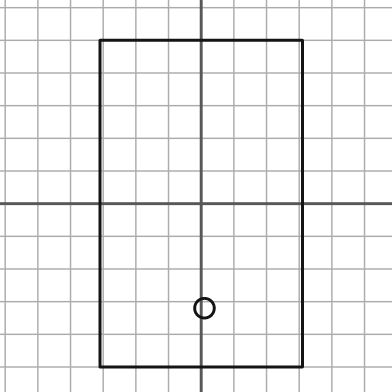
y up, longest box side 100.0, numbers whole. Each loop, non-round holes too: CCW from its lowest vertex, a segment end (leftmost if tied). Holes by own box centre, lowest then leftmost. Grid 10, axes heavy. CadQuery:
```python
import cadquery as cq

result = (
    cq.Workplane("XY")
    .moveTo(-31.0, -50.0)
    .lineTo(31.0, -50.0)
    .lineTo(31.0, 50.0)
    .lineTo(-31.0, 50.0)
    .close()
    .moveTo(1.0, -32.0)
    .circle(3.0)
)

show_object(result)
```